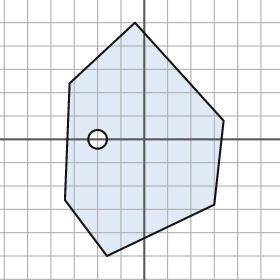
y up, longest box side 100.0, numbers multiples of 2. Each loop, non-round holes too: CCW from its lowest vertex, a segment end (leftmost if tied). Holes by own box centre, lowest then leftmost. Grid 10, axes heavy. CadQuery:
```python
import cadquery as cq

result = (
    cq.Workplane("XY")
    .moveTo(-16.0, -50.0)
    .lineTo(30.0, -28.0)
    .lineTo(34.0, 8.0)
    .lineTo(-4.0, 50.0)
    .lineTo(-32.0, 24.0)
    .lineTo(-34.0, -26.0)
    .close()
    .moveTo(-20.0, 0.0)
    .circle(4.0)
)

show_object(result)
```